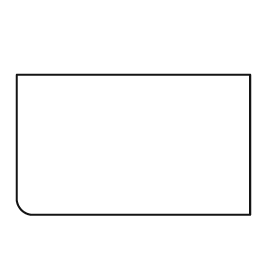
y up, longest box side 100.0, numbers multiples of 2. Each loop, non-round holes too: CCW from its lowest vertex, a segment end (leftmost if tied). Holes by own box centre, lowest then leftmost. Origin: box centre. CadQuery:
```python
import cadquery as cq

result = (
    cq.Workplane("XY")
    .moveTo(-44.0, -30.0)
    .lineTo(50.0, -30.0)
    .lineTo(50.0, 30.0)
    .lineTo(-50.0, 30.0)
    .lineTo(-50.0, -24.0)
    .threePointArc((-48.0, -28.0), (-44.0, -30.0))
    .close()
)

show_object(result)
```